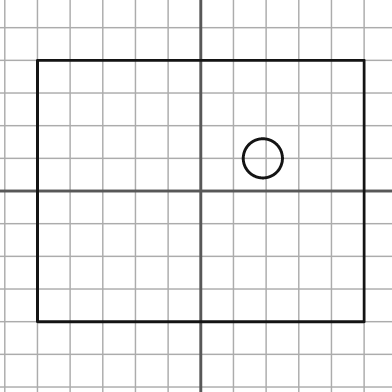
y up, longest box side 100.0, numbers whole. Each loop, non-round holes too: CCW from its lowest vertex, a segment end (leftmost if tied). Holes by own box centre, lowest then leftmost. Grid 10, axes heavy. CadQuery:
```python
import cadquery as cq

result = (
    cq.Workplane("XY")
    .moveTo(-50.0, -40.0)
    .lineTo(50.0, -40.0)
    .lineTo(50.0, 40.0)
    .lineTo(-50.0, 40.0)
    .close()
    .moveTo(19.0, 10.0)
    .circle(6.0)
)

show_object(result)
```